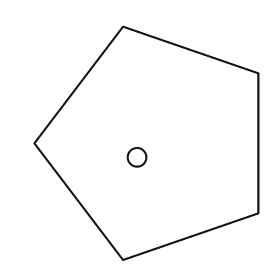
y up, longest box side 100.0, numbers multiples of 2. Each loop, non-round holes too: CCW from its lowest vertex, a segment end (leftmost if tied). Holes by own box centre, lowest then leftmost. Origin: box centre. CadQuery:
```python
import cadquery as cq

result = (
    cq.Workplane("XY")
    .moveTo(-10.0, -50.0)
    .lineTo(48.0, -30.0)
    .lineTo(48.0, 30.0)
    .lineTo(-10.0, 50.0)
    .lineTo(-48.0, 0.0)
    .close()
    .moveTo(-4.0, -6.0)
    .circle(4.0)
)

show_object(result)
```